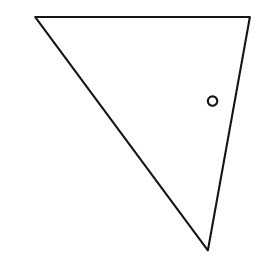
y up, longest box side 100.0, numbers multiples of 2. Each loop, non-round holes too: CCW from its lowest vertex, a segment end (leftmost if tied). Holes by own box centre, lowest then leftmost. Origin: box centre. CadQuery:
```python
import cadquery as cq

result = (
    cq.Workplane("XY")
    .moveTo(28.0, -50.0)
    .lineTo(46.0, 50.0)
    .lineTo(-46.0, 50.0)
    .close()
    .moveTo(30.0, 14.0)
    .circle(2.0)
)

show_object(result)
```